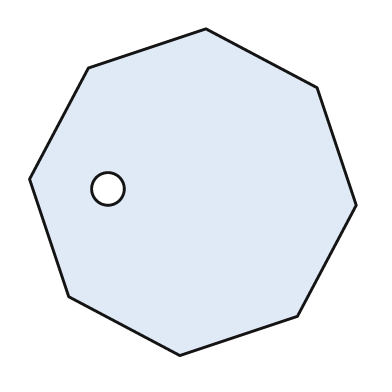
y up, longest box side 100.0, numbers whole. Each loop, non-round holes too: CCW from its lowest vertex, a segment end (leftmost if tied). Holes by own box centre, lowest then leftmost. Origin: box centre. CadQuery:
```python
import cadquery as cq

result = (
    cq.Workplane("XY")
    .moveTo(-4.0, -50.0)
    .lineTo(32.0, -38.0)
    .lineTo(50.0, -4.0)
    .lineTo(38.0, 32.0)
    .lineTo(4.0, 50.0)
    .lineTo(-32.0, 38.0)
    .lineTo(-50.0, 4.0)
    .lineTo(-38.0, -32.0)
    .close()
    .moveTo(-26.0, 1.0)
    .circle(5.0)
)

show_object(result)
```